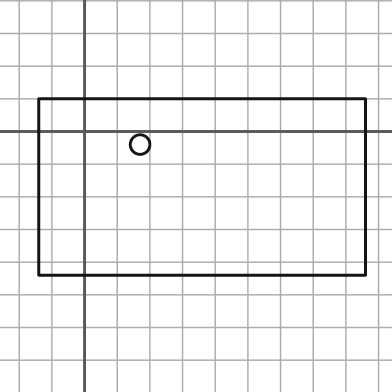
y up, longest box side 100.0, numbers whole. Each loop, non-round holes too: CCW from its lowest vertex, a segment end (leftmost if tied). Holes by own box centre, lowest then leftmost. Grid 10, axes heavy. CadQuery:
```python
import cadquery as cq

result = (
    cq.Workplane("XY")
    .moveTo(-14.0, -44.0)
    .lineTo(86.0, -44.0)
    .lineTo(86.0, 10.0)
    .lineTo(-14.0, 10.0)
    .close()
    .moveTo(17.0, -4.0)
    .circle(3.0)
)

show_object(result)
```